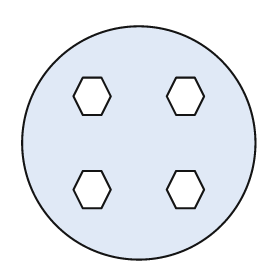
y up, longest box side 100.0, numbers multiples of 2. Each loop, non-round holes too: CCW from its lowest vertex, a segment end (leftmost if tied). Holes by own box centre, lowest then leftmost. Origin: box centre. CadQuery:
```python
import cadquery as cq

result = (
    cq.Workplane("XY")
    .moveTo(0.0, 0.0)
    .circle(50.0)
    .moveTo(-24.0, -28.0)
    .lineTo(-16.0, -28.0)
    .lineTo(-12.0, -20.0)
    .lineTo(-16.0, -12.0)
    .lineTo(-24.0, -12.0)
    .lineTo(-28.0, -20.0)
    .close()
    .moveTo(16.0, -28.0)
    .lineTo(24.0, -28.0)
    .lineTo(28.0, -20.0)
    .lineTo(24.0, -12.0)
    .lineTo(16.0, -12.0)
    .lineTo(12.0, -20.0)
    .close()
    .moveTo(-24.0, 12.0)
    .lineTo(-16.0, 12.0)
    .lineTo(-12.0, 20.0)
    .lineTo(-16.0, 28.0)
    .lineTo(-24.0, 28.0)
    .lineTo(-28.0, 20.0)
    .close()
    .moveTo(16.0, 12.0)
    .lineTo(24.0, 12.0)
    .lineTo(28.0, 20.0)
    .lineTo(24.0, 28.0)
    .lineTo(16.0, 28.0)
    .lineTo(12.0, 20.0)
    .close()
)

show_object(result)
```